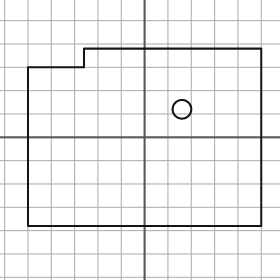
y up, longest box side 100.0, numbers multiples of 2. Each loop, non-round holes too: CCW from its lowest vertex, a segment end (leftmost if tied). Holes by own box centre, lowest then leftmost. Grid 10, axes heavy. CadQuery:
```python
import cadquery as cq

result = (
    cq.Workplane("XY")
    .moveTo(-50.0, -38.0)
    .lineTo(50.0, -38.0)
    .lineTo(50.0, 38.0)
    .lineTo(-26.0, 38.0)
    .lineTo(-26.0, 30.0)
    .lineTo(-50.0, 30.0)
    .close()
    .moveTo(16.0, 12.0)
    .circle(4.0)
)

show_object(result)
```